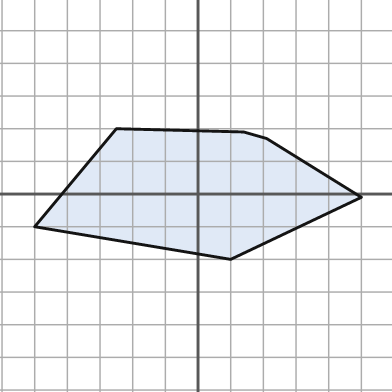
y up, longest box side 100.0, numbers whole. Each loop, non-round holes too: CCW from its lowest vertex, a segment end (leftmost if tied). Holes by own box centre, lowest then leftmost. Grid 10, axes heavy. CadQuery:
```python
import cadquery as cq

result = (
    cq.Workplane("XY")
    .moveTo(10.0, -20.0)
    .lineTo(50.0, -1.0)
    .lineTo(21.0, 17.0)
    .lineTo(14.0, 19.0)
    .lineTo(-25.0, 20.0)
    .lineTo(-50.0, -10.0)
    .close()
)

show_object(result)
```